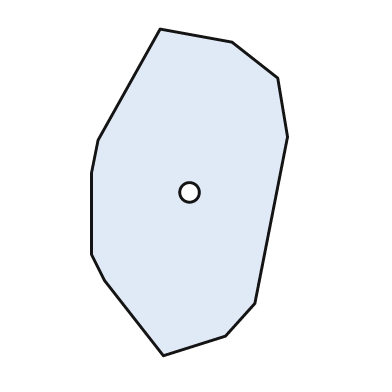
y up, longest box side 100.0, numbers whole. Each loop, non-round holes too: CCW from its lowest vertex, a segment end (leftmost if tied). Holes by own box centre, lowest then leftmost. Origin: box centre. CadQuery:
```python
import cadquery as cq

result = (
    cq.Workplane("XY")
    .moveTo(-8.0, -50.0)
    .lineTo(11.0, -44.0)
    .lineTo(20.0, -34.0)
    .lineTo(30.0, 17.0)
    .lineTo(27.0, 35.0)
    .lineTo(13.0, 46.0)
    .lineTo(-9.0, 50.0)
    .lineTo(-28.0, 16.0)
    .lineTo(-30.0, 6.0)
    .lineTo(-30.0, -19.0)
    .lineTo(-26.0, -27.0)
    .close()
    .moveTo(0.0, 0.0)
    .circle(3.0)
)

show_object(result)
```